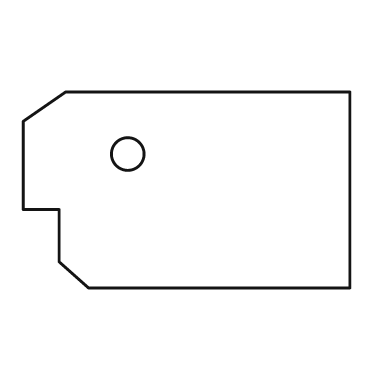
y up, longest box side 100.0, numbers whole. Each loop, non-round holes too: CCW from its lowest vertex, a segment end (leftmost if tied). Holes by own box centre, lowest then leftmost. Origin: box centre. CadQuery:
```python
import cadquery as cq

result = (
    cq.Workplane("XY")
    .moveTo(-30.0, -30.0)
    .lineTo(50.0, -30.0)
    .lineTo(50.0, 30.0)
    .lineTo(-37.0, 30.0)
    .lineTo(-50.0, 21.0)
    .lineTo(-50.0, -6.0)
    .lineTo(-39.0, -6.0)
    .lineTo(-39.0, -22.0)
    .close()
    .moveTo(-18.0, 11.0)
    .circle(5.0)
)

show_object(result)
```